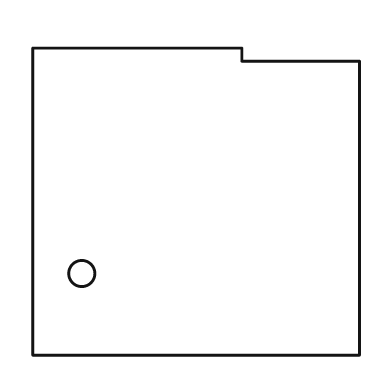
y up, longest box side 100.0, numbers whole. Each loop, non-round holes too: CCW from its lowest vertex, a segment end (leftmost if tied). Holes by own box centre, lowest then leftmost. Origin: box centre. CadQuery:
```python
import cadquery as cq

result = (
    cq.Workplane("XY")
    .moveTo(-50.0, -47.0)
    .lineTo(50.0, -47.0)
    .lineTo(50.0, 43.0)
    .lineTo(14.0, 43.0)
    .lineTo(14.0, 47.0)
    .lineTo(-50.0, 47.0)
    .close()
    .moveTo(-35.0, -22.0)
    .circle(4.0)
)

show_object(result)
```